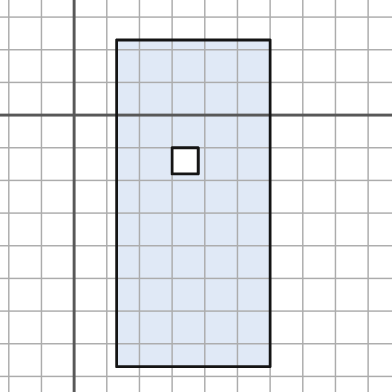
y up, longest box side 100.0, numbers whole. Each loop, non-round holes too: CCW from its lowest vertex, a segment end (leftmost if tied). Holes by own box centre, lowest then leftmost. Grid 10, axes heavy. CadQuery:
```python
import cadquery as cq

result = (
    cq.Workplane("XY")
    .moveTo(13.0, -77.0)
    .lineTo(60.0, -77.0)
    .lineTo(60.0, 23.0)
    .lineTo(13.0, 23.0)
    .close()
    .moveTo(30.0, -18.0)
    .lineTo(38.0, -18.0)
    .lineTo(38.0, -10.0)
    .lineTo(30.0, -10.0)
    .close()
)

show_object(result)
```